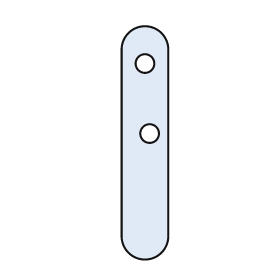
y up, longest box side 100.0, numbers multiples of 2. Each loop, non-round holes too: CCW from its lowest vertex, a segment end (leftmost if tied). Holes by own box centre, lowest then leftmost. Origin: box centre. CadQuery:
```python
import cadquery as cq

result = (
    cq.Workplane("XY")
    .moveTo(-10.0, -40.0)
    .threePointArc((0.0, -50.0), (10.0, -40.0))
    .lineTo(10.0, 40.0)
    .threePointArc((0.0, 50.0), (-10.0, 40.0))
    .close()
    .moveTo(2.0, 4.0)
    .circle(4.0)
    .moveTo(0.0, 34.0)
    .circle(4.0)
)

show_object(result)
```